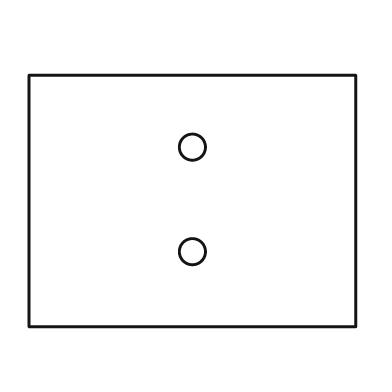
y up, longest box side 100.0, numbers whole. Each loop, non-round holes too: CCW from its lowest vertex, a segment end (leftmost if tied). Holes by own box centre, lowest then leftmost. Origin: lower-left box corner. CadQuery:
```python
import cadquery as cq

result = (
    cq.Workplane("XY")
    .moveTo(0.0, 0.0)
    .lineTo(100.0, 0.0)
    .lineTo(100.0, 77.0)
    .lineTo(0.0, 77.0)
    .close()
    .moveTo(50.0, 23.0)
    .circle(4.0)
    .moveTo(50.0, 55.0)
    .circle(4.0)
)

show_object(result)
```